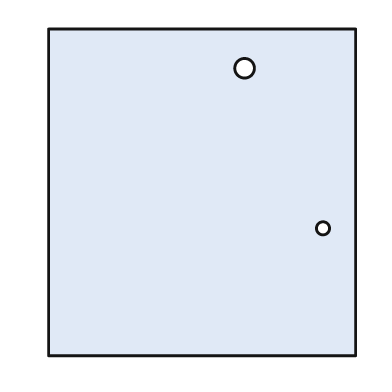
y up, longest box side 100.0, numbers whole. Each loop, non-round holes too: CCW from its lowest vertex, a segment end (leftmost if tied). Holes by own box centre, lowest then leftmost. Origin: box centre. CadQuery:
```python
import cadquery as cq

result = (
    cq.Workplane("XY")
    .moveTo(-47.0, -50.0)
    .lineTo(47.0, -50.0)
    .lineTo(47.0, 50.0)
    .lineTo(-47.0, 50.0)
    .close()
    .moveTo(37.0, -11.0)
    .circle(2.0)
    .moveTo(13.0, 38.0)
    .circle(3.0)
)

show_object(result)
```